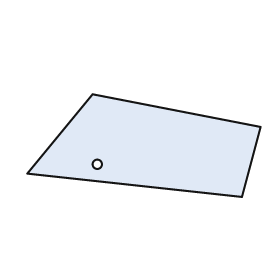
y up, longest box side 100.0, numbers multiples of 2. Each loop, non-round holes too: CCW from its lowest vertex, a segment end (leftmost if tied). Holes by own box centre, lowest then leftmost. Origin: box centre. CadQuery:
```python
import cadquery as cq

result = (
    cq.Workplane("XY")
    .moveTo(42.0, -22.0)
    .lineTo(50.0, 8.0)
    .lineTo(-22.0, 22.0)
    .lineTo(-50.0, -12.0)
    .close()
    .moveTo(-20.0, -8.0)
    .circle(2.0)
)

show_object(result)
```